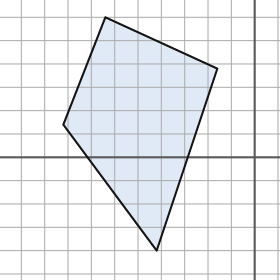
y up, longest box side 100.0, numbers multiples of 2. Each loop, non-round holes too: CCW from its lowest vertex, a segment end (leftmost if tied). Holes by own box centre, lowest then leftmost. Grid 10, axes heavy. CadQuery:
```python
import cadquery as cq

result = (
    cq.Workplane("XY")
    .moveTo(-42.0, -40.0)
    .lineTo(-16.0, 38.0)
    .lineTo(-64.0, 60.0)
    .lineTo(-82.0, 14.0)
    .close()
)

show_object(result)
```